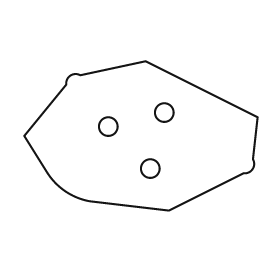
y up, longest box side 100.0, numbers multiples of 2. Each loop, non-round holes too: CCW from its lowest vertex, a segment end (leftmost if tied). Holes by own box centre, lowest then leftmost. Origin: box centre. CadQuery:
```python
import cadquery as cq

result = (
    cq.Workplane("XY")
    .moveTo(12.0, -32.0)
    .lineTo(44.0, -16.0)
    .threePointArc((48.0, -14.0), (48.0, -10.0))
    .lineTo(50.0, 8.0)
    .lineTo(2.0, 32.0)
    .lineTo(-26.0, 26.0)
    .threePointArc((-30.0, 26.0), (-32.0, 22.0))
    .lineTo(-50.0, 0.0)
    .lineTo(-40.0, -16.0)
    .threePointArc((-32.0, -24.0), (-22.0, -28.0))
    .close()
    .moveTo(4.0, -14.0)
    .circle(4.0)
    .moveTo(-14.0, 4.0)
    .circle(4.0)
    .moveTo(10.0, 10.0)
    .circle(4.0)
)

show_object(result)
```